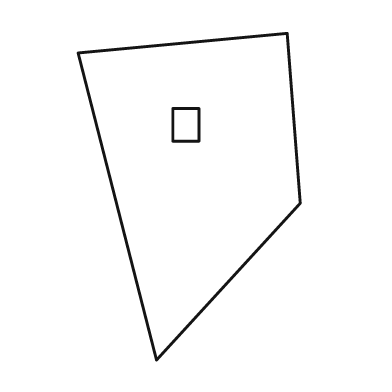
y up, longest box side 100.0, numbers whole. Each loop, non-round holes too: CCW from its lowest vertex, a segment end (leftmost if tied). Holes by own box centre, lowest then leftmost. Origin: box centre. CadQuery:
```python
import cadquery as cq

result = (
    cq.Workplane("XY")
    .moveTo(-10.0, -50.0)
    .lineTo(34.0, -2.0)
    .lineTo(30.0, 50.0)
    .lineTo(-34.0, 44.0)
    .close()
    .moveTo(-5.0, 17.0)
    .lineTo(3.0, 17.0)
    .lineTo(3.0, 27.0)
    .lineTo(-5.0, 27.0)
    .close()
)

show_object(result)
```